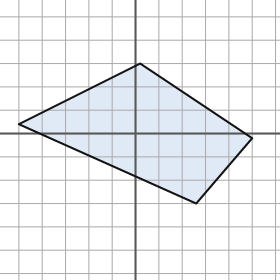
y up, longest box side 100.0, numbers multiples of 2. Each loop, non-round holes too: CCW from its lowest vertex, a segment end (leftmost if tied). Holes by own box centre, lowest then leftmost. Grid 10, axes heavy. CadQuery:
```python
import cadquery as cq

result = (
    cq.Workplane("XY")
    .moveTo(26.0, -30.0)
    .lineTo(50.0, -2.0)
    .lineTo(2.0, 30.0)
    .lineTo(-50.0, 4.0)
    .close()
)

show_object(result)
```